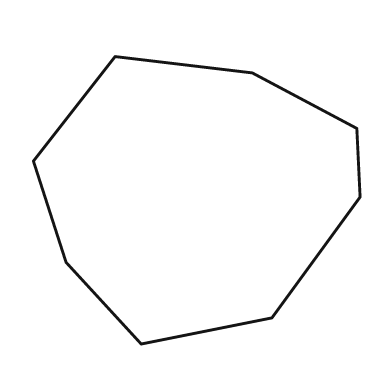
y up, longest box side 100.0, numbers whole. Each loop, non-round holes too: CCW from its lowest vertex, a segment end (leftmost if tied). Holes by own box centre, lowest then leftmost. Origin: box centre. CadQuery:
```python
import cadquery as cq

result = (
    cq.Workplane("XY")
    .moveTo(-17.0, -44.0)
    .lineTo(23.0, -36.0)
    .lineTo(50.0, 1.0)
    .lineTo(49.0, 22.0)
    .lineTo(17.0, 39.0)
    .lineTo(-25.0, 44.0)
    .lineTo(-50.0, 12.0)
    .lineTo(-40.0, -19.0)
    .close()
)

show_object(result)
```